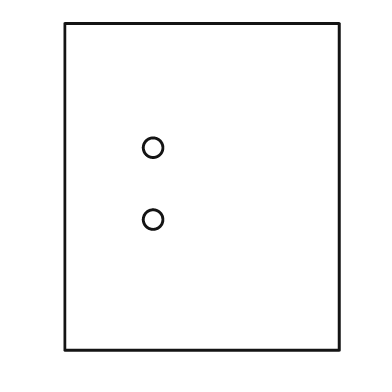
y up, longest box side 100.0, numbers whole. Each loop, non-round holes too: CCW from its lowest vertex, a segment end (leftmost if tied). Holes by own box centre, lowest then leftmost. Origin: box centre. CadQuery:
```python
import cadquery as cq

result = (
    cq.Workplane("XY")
    .moveTo(-42.0, -50.0)
    .lineTo(42.0, -50.0)
    .lineTo(42.0, 50.0)
    .lineTo(-42.0, 50.0)
    .close()
    .moveTo(-15.0, -10.0)
    .circle(3.0)
    .moveTo(-15.0, 12.0)
    .circle(3.0)
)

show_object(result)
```